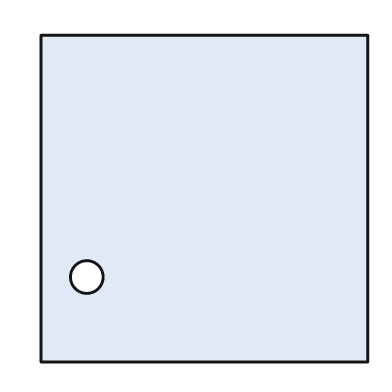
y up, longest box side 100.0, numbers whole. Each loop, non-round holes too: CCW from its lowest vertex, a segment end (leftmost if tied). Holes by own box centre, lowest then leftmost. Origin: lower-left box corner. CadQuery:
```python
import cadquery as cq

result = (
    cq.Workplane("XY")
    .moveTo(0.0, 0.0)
    .lineTo(100.0, 0.0)
    .lineTo(100.0, 100.0)
    .lineTo(0.0, 100.0)
    .close()
    .moveTo(14.0, 26.0)
    .circle(5.0)
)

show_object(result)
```